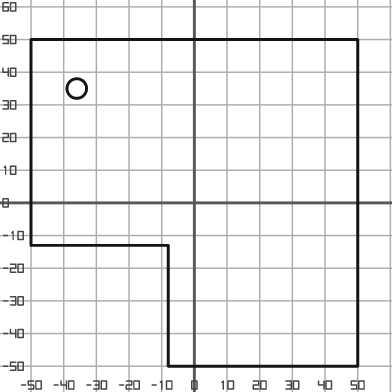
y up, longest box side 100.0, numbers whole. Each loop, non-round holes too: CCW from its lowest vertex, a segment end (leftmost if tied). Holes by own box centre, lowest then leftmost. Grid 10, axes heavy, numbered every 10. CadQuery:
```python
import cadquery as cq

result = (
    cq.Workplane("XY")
    .moveTo(-8.0, -50.0)
    .lineTo(50.0, -50.0)
    .lineTo(50.0, 50.0)
    .lineTo(-50.0, 50.0)
    .lineTo(-50.0, -13.0)
    .lineTo(-8.0, -13.0)
    .close()
    .moveTo(-36.0, 35.0)
    .circle(3.0)
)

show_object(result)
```